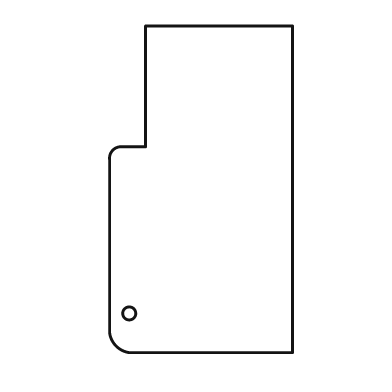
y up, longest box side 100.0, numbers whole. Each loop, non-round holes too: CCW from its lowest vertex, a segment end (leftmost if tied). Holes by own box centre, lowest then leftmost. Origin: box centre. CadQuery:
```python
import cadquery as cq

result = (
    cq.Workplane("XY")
    .moveTo(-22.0, -50.0)
    .lineTo(28.0, -50.0)
    .lineTo(28.0, 50.0)
    .lineTo(-17.0, 50.0)
    .lineTo(-17.0, 13.0)
    .lineTo(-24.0, 13.0)
    .threePointArc((-27.0, 12.0), (-28.0, 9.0))
    .lineTo(-28.0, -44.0)
    .threePointArc((-26.0, -48.0), (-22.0, -50.0))
    .close()
    .moveTo(-22.0, -38.0)
    .circle(2.0)
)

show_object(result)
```